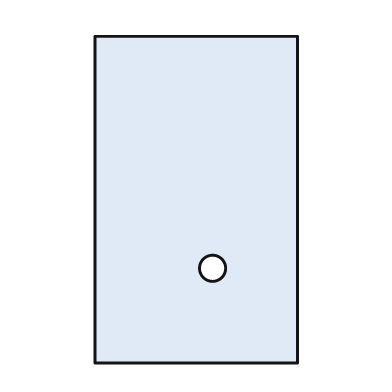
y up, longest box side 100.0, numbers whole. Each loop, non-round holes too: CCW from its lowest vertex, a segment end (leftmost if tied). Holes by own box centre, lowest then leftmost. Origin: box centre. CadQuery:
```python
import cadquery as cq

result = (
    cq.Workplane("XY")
    .moveTo(-31.0, -50.0)
    .lineTo(31.0, -50.0)
    .lineTo(31.0, 50.0)
    .lineTo(-31.0, 50.0)
    .close()
    .moveTo(5.0, -21.0)
    .circle(4.0)
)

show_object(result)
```